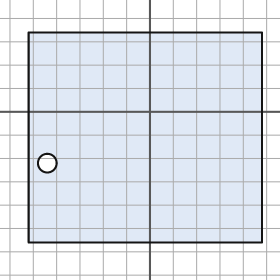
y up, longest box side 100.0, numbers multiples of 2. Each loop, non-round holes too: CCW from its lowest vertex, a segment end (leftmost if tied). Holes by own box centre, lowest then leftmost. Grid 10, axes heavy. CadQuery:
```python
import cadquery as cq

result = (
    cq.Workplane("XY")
    .moveTo(-52.0, -56.0)
    .lineTo(48.0, -56.0)
    .lineTo(48.0, 34.0)
    .lineTo(-52.0, 34.0)
    .close()
    .moveTo(-44.0, -22.0)
    .circle(4.0)
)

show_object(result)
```